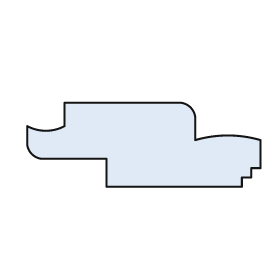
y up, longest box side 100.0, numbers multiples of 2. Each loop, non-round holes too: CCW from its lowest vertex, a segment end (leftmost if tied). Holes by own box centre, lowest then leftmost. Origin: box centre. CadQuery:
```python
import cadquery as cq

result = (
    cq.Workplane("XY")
    .moveTo(-16.0, -18.0)
    .lineTo(42.0, -18.0)
    .lineTo(42.0, -14.0)
    .lineTo(46.0, -14.0)
    .lineTo(46.0, -10.0)
    .lineTo(50.0, -10.0)
    .lineTo(50.0, 2.0)
    .threePointArc((36.0, 4.0), (22.0, 2.0))
    .lineTo(22.0, 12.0)
    .threePointArc((20.0, 16.0), (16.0, 18.0))
    .lineTo(-34.0, 18.0)
    .lineTo(-34.0, 8.0)
    .threePointArc((-42.0, 6.0), (-50.0, 8.0))
    .lineTo(-50.0, 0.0)
    .threePointArc((-48.0, -4.0), (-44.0, -6.0))
    .lineTo(-16.0, -6.0)
    .close()
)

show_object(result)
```